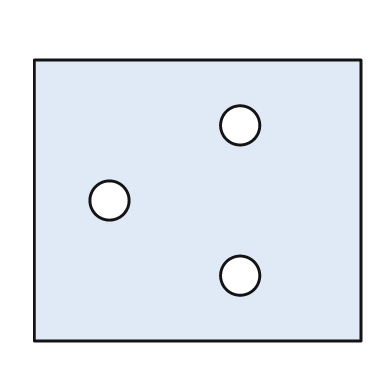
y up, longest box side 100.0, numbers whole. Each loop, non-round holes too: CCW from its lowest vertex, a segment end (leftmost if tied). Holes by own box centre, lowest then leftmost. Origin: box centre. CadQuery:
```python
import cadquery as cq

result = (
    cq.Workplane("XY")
    .moveTo(-50.0, -43.0)
    .lineTo(50.0, -43.0)
    .lineTo(50.0, 43.0)
    .lineTo(-50.0, 43.0)
    .close()
    .moveTo(13.0, -23.0)
    .circle(6.0)
    .moveTo(-27.0, 0.0)
    .circle(6.0)
    .moveTo(13.0, 23.0)
    .circle(6.0)
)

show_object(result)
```